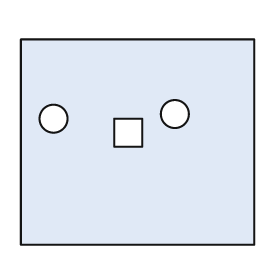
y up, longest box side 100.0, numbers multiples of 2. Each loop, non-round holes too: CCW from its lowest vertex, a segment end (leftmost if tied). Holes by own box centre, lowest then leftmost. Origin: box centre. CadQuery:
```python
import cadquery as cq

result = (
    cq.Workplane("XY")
    .moveTo(-50.0, -44.0)
    .lineTo(50.0, -44.0)
    .lineTo(50.0, 44.0)
    .lineTo(-50.0, 44.0)
    .close()
    .moveTo(-10.0, -2.0)
    .lineTo(2.0, -2.0)
    .lineTo(2.0, 10.0)
    .lineTo(-10.0, 10.0)
    .close()
    .moveTo(-36.0, 10.0)
    .circle(6.0)
    .moveTo(16.0, 12.0)
    .circle(6.0)
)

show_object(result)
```